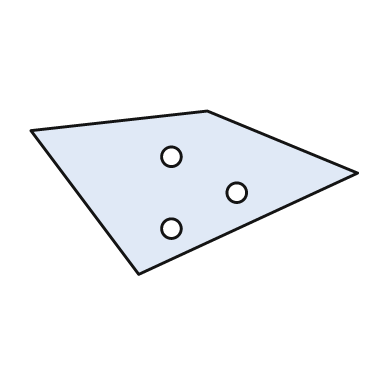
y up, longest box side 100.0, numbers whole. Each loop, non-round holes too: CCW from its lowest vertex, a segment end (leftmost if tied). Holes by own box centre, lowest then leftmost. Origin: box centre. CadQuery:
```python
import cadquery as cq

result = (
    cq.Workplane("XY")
    .moveTo(-17.0, -25.0)
    .lineTo(50.0, 6.0)
    .lineTo(4.0, 25.0)
    .lineTo(-50.0, 19.0)
    .close()
    .moveTo(-7.0, -11.0)
    .circle(3.0)
    .moveTo(13.0, 0.0)
    .circle(3.0)
    .moveTo(-7.0, 11.0)
    .circle(3.0)
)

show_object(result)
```